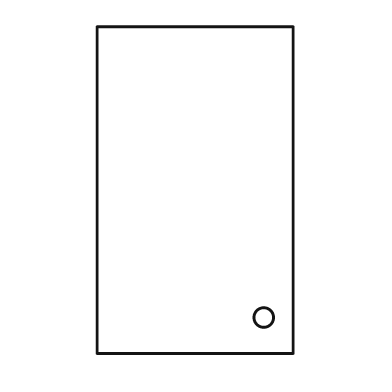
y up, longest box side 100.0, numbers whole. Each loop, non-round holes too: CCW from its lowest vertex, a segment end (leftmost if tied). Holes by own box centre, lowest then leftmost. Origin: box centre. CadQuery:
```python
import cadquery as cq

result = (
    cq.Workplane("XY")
    .moveTo(-30.0, -50.0)
    .lineTo(30.0, -50.0)
    .lineTo(30.0, 50.0)
    .lineTo(-30.0, 50.0)
    .close()
    .moveTo(21.0, -39.0)
    .circle(3.0)
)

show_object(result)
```